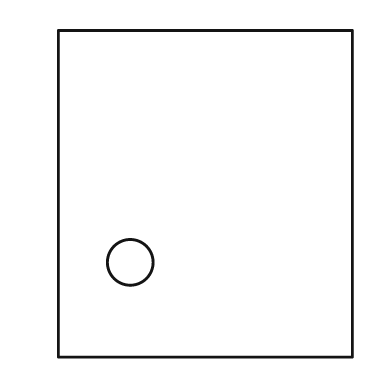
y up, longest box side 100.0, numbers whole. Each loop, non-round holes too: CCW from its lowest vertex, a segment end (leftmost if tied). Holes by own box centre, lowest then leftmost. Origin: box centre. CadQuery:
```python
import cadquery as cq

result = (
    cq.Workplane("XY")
    .moveTo(-45.0, -50.0)
    .lineTo(45.0, -50.0)
    .lineTo(45.0, 50.0)
    .lineTo(-45.0, 50.0)
    .close()
    .moveTo(-23.0, -21.0)
    .circle(7.0)
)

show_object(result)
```